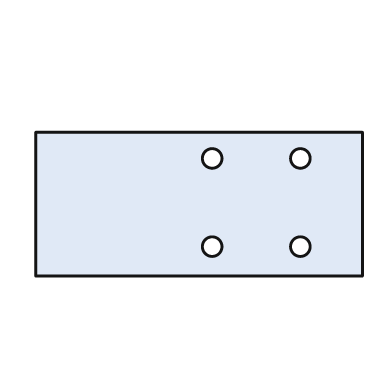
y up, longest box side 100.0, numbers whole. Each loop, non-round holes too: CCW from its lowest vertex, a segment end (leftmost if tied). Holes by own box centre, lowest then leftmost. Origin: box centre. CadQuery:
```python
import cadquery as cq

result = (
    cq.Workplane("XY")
    .moveTo(-50.0, -22.0)
    .lineTo(50.0, -22.0)
    .lineTo(50.0, 22.0)
    .lineTo(-50.0, 22.0)
    .close()
    .moveTo(4.0, -13.0)
    .circle(3.0)
    .moveTo(31.0, -13.0)
    .circle(3.0)
    .moveTo(4.0, 14.0)
    .circle(3.0)
    .moveTo(31.0, 14.0)
    .circle(3.0)
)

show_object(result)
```